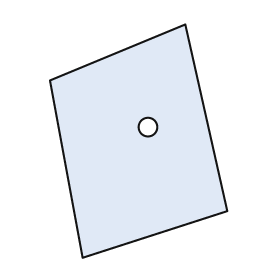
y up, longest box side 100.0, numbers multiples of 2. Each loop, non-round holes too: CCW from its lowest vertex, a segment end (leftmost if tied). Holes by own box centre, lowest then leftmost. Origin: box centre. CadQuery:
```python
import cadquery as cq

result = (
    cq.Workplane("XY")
    .moveTo(-24.0, -50.0)
    .lineTo(38.0, -30.0)
    .lineTo(20.0, 50.0)
    .lineTo(-38.0, 26.0)
    .close()
    .moveTo(4.0, 6.0)
    .circle(4.0)
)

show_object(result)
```